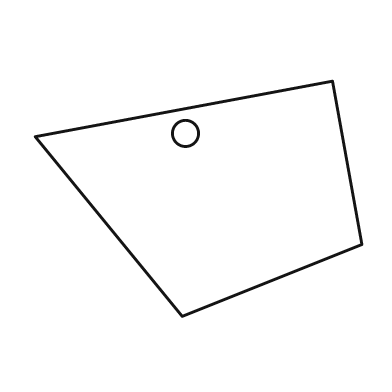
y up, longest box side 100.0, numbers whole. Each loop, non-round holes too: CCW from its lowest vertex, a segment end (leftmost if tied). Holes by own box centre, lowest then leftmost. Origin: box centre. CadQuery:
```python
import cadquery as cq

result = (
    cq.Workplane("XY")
    .moveTo(-5.0, -36.0)
    .lineTo(50.0, -14.0)
    .lineTo(41.0, 36.0)
    .lineTo(-50.0, 19.0)
    .close()
    .moveTo(-4.0, 20.0)
    .circle(4.0)
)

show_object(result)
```